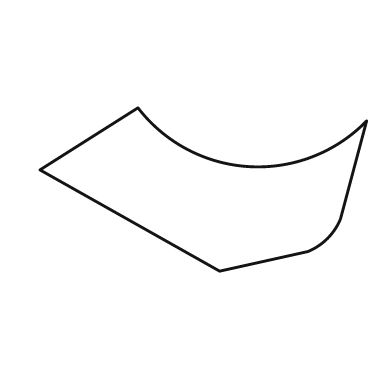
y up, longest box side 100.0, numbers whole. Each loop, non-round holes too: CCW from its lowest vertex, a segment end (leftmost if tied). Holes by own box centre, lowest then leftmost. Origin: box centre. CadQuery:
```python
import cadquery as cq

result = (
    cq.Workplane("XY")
    .moveTo(5.0, -25.0)
    .lineTo(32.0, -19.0)
    .threePointArc((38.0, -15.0), (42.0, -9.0))
    .lineTo(50.0, 21.0)
    .threePointArc((14.0, 7.0), (-20.0, 25.0))
    .lineTo(-50.0, 6.0)
    .close()
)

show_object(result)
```